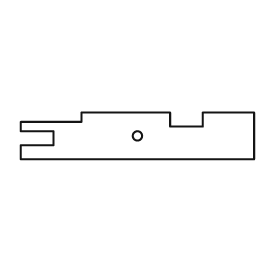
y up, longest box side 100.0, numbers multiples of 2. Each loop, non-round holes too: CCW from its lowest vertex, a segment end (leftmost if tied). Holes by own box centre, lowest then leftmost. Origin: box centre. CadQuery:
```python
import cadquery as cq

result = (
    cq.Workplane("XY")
    .moveTo(-50.0, -10.0)
    .lineTo(50.0, -10.0)
    .lineTo(50.0, 10.0)
    .lineTo(28.0, 10.0)
    .lineTo(28.0, 4.0)
    .lineTo(14.0, 4.0)
    .lineTo(14.0, 10.0)
    .lineTo(-24.0, 10.0)
    .lineTo(-24.0, 6.0)
    .lineTo(-50.0, 6.0)
    .lineTo(-50.0, 2.0)
    .lineTo(-36.0, 2.0)
    .lineTo(-36.0, -4.0)
    .lineTo(-50.0, -4.0)
    .close()
    .moveTo(0.0, 0.0)
    .circle(2.0)
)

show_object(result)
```